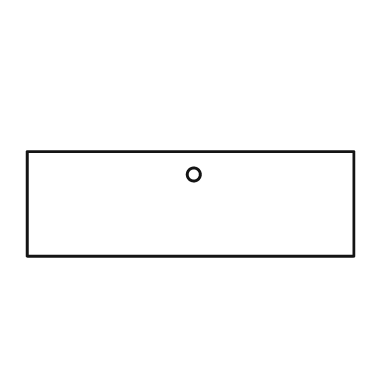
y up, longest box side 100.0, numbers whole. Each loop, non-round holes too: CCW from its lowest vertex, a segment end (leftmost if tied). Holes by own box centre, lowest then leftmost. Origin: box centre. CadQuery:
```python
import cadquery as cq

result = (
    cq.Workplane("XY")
    .moveTo(-50.0, -16.0)
    .lineTo(50.0, -16.0)
    .lineTo(50.0, 16.0)
    .lineTo(-50.0, 16.0)
    .close()
    .moveTo(1.0, 9.0)
    .circle(2.0)
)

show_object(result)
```